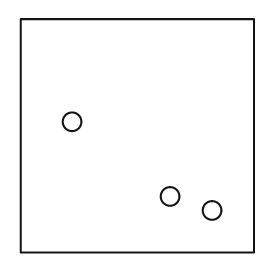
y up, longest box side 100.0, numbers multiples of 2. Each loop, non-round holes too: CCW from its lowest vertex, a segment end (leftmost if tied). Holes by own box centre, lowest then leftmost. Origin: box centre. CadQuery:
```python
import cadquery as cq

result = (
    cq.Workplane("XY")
    .moveTo(-50.0, -50.0)
    .lineTo(50.0, -50.0)
    .lineTo(50.0, 50.0)
    .lineTo(-50.0, 50.0)
    .close()
    .moveTo(32.0, -32.0)
    .circle(4.0)
    .moveTo(14.0, -26.0)
    .circle(4.0)
    .moveTo(-28.0, 6.0)
    .circle(4.0)
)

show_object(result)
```